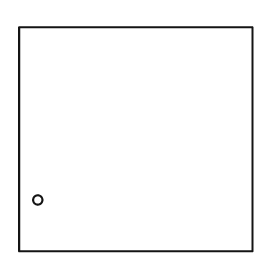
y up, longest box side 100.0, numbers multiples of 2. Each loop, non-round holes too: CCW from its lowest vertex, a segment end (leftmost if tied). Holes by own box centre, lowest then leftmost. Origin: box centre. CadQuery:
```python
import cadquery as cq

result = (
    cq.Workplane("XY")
    .moveTo(-50.0, -48.0)
    .lineTo(50.0, -48.0)
    .lineTo(50.0, 48.0)
    .lineTo(-50.0, 48.0)
    .close()
    .moveTo(-42.0, -26.0)
    .circle(2.0)
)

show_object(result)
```